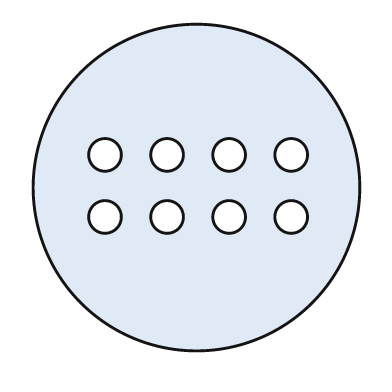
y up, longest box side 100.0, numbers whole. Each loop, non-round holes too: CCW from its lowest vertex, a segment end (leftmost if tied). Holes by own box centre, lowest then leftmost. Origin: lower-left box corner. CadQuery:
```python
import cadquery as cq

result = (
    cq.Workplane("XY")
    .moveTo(50.0, 50.0)
    .circle(50.0)
    .moveTo(22.0, 41.0)
    .circle(5.0)
    .moveTo(41.0, 41.0)
    .circle(5.0)
    .moveTo(60.0, 41.0)
    .circle(5.0)
    .moveTo(79.0, 41.0)
    .circle(5.0)
    .moveTo(22.0, 60.0)
    .circle(5.0)
    .moveTo(41.0, 60.0)
    .circle(5.0)
    .moveTo(60.0, 60.0)
    .circle(5.0)
    .moveTo(79.0, 60.0)
    .circle(5.0)
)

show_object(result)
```